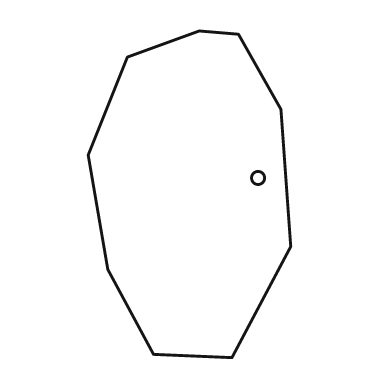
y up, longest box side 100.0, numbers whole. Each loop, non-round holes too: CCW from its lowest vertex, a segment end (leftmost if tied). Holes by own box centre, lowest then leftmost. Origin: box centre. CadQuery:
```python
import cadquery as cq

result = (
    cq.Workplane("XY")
    .moveTo(13.0, -50.0)
    .lineTo(31.0, -16.0)
    .lineTo(28.0, 26.0)
    .lineTo(15.0, 49.0)
    .lineTo(3.0, 50.0)
    .lineTo(-19.0, 42.0)
    .lineTo(-31.0, 12.0)
    .lineTo(-25.0, -23.0)
    .lineTo(-11.0, -49.0)
    .close()
    .moveTo(21.0, 5.0)
    .circle(2.0)
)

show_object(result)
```